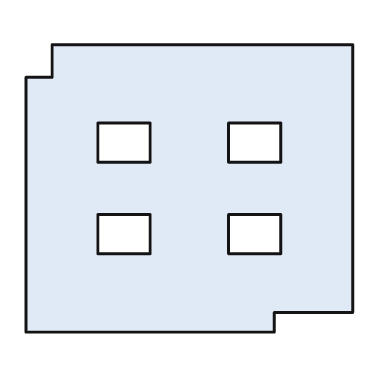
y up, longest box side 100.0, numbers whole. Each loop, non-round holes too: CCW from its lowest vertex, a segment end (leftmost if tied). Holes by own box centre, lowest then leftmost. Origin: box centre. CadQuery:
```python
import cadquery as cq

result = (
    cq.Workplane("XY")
    .moveTo(-50.0, -44.0)
    .lineTo(26.0, -44.0)
    .lineTo(26.0, -38.0)
    .lineTo(50.0, -38.0)
    .lineTo(50.0, 44.0)
    .lineTo(-42.0, 44.0)
    .lineTo(-42.0, 34.0)
    .lineTo(-50.0, 34.0)
    .close()
    .moveTo(-28.0, -20.0)
    .lineTo(-12.0, -20.0)
    .lineTo(-12.0, -8.0)
    .lineTo(-28.0, -8.0)
    .close()
    .moveTo(12.0, -20.0)
    .lineTo(28.0, -20.0)
    .lineTo(28.0, -8.0)
    .lineTo(12.0, -8.0)
    .close()
    .moveTo(-28.0, 8.0)
    .lineTo(-12.0, 8.0)
    .lineTo(-12.0, 20.0)
    .lineTo(-28.0, 20.0)
    .close()
    .moveTo(12.0, 8.0)
    .lineTo(28.0, 8.0)
    .lineTo(28.0, 20.0)
    .lineTo(12.0, 20.0)
    .close()
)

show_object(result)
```